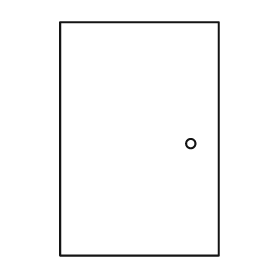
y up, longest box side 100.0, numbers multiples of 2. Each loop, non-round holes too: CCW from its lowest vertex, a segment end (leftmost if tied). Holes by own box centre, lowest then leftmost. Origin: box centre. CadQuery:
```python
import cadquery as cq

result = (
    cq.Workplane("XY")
    .moveTo(-34.0, -50.0)
    .lineTo(34.0, -50.0)
    .lineTo(34.0, 50.0)
    .lineTo(-34.0, 50.0)
    .close()
    .moveTo(22.0, -2.0)
    .circle(2.0)
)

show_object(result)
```